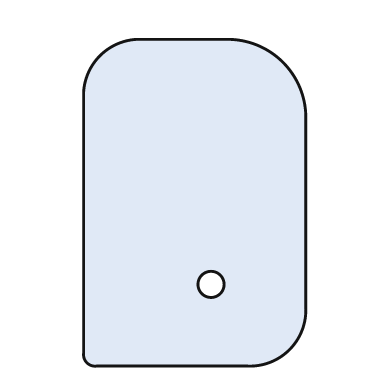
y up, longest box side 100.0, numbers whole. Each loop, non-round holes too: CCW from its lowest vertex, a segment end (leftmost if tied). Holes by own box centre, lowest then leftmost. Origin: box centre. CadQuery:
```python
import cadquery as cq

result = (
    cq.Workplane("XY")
    .moveTo(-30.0, -50.0)
    .lineTo(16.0, -50.0)
    .threePointArc((29.0, -45.0), (34.0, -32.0))
    .lineTo(34.0, 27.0)
    .threePointArc((27.0, 43.0), (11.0, 50.0))
    .lineTo(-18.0, 50.0)
    .threePointArc((-29.0, 45.0), (-34.0, 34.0))
    .lineTo(-34.0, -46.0)
    .threePointArc((-33.0, -49.0), (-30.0, -50.0))
    .close()
    .moveTo(5.0, -25.0)
    .circle(4.0)
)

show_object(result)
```